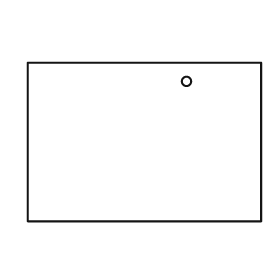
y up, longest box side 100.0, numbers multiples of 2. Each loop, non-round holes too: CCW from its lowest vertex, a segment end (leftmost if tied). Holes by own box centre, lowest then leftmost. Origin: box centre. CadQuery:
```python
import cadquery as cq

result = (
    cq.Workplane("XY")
    .moveTo(-50.0, -34.0)
    .lineTo(50.0, -34.0)
    .lineTo(50.0, 34.0)
    .lineTo(-50.0, 34.0)
    .close()
    .moveTo(18.0, 26.0)
    .circle(2.0)
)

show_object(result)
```